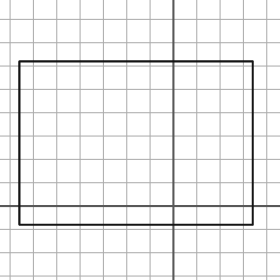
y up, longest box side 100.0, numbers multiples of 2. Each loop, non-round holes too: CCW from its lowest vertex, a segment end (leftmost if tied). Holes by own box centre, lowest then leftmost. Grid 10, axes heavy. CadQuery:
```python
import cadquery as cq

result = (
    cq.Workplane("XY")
    .moveTo(-66.0, -8.0)
    .lineTo(34.0, -8.0)
    .lineTo(34.0, 62.0)
    .lineTo(-66.0, 62.0)
    .close()
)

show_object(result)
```